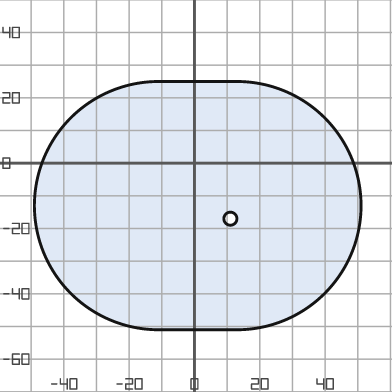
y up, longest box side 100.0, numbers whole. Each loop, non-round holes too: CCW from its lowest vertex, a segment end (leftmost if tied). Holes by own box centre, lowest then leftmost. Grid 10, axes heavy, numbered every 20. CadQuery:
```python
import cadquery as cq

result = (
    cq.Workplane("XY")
    .moveTo(-11.0, -51.0)
    .lineTo(13.0, -51.0)
    .threePointArc((51.0, -13.0), (13.0, 25.0))
    .lineTo(-11.0, 25.0)
    .threePointArc((-49.0, -13.0), (-11.0, -51.0))
    .close()
    .moveTo(11.0, -17.0)
    .circle(2.0)
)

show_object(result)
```